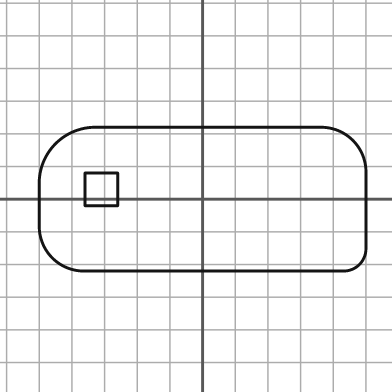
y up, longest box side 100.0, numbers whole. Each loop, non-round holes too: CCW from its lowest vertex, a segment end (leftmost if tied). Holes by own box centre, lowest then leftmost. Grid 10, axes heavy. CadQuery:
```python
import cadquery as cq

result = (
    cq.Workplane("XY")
    .moveTo(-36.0, -22.0)
    .lineTo(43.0, -22.0)
    .threePointArc((48.0, -20.0), (50.0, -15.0))
    .lineTo(50.0, 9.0)
    .threePointArc((46.0, 18.0), (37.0, 22.0))
    .lineTo(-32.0, 22.0)
    .threePointArc((-45.0, 17.0), (-50.0, 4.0))
    .lineTo(-50.0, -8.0)
    .threePointArc((-46.0, -18.0), (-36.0, -22.0))
    .close()
    .moveTo(-36.0, -2.0)
    .lineTo(-26.0, -2.0)
    .lineTo(-26.0, 8.0)
    .lineTo(-36.0, 8.0)
    .close()
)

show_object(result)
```